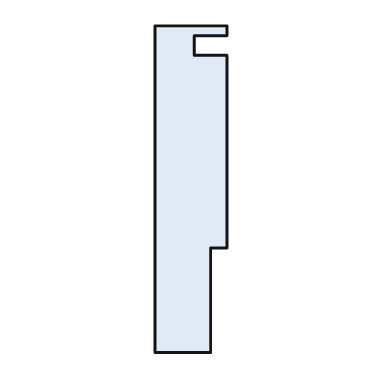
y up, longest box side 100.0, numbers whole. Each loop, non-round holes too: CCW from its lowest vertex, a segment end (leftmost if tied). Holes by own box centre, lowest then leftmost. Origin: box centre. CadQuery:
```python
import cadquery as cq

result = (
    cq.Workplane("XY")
    .moveTo(-11.0, -50.0)
    .lineTo(6.0, -50.0)
    .lineTo(6.0, -18.0)
    .lineTo(11.0, -18.0)
    .lineTo(11.0, 41.0)
    .lineTo(1.0, 41.0)
    .lineTo(1.0, 47.0)
    .lineTo(11.0, 47.0)
    .lineTo(11.0, 50.0)
    .lineTo(-11.0, 50.0)
    .close()
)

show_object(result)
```